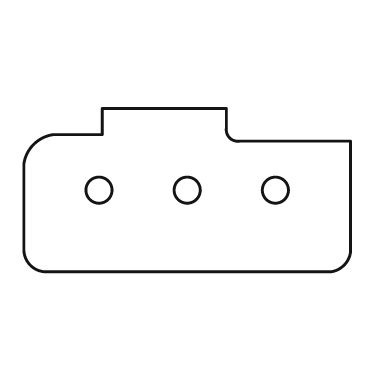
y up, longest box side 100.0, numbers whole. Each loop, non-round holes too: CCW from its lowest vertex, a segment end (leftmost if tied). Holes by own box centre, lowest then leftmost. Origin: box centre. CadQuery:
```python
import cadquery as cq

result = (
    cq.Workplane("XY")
    .moveTo(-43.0, -25.0)
    .lineTo(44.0, -25.0)
    .threePointArc((48.0, -23.0), (50.0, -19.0))
    .lineTo(50.0, 15.0)
    .lineTo(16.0, 15.0)
    .threePointArc((13.0, 16.0), (12.0, 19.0))
    .lineTo(12.0, 25.0)
    .lineTo(-26.0, 25.0)
    .lineTo(-26.0, 17.0)
    .lineTo(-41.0, 17.0)
    .threePointArc((-47.0, 14.0), (-50.0, 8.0))
    .lineTo(-50.0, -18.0)
    .threePointArc((-48.0, -23.0), (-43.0, -25.0))
    .close()
    .moveTo(-27.0, 0.0)
    .circle(4.0)
    .moveTo(0.0, 0.0)
    .circle(4.0)
    .moveTo(27.0, 0.0)
    .circle(4.0)
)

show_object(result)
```